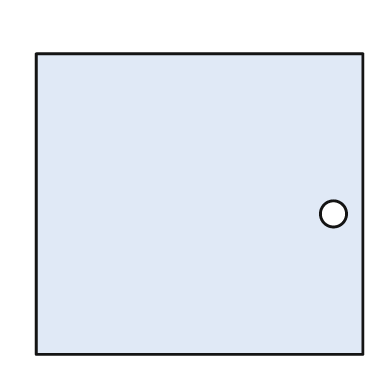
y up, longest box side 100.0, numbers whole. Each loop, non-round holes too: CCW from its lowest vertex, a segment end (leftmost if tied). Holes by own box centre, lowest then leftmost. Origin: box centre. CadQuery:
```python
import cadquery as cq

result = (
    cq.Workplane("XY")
    .moveTo(-50.0, -46.0)
    .lineTo(50.0, -46.0)
    .lineTo(50.0, 46.0)
    .lineTo(-50.0, 46.0)
    .close()
    .moveTo(41.0, -3.0)
    .circle(4.0)
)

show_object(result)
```